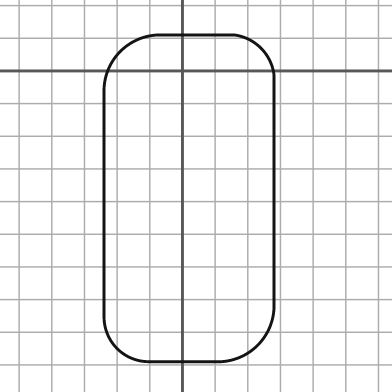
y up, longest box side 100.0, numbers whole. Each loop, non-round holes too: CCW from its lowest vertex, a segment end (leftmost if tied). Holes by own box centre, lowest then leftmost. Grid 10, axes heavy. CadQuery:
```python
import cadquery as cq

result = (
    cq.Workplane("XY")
    .moveTo(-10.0, -89.0)
    .lineTo(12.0, -89.0)
    .threePointArc((23.0, -84.0), (28.0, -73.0))
    .lineTo(28.0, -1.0)
    .threePointArc((24.0, 7.0), (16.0, 11.0))
    .lineTo(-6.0, 11.0)
    .threePointArc((-19.0, 6.0), (-24.0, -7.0))
    .lineTo(-24.0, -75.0)
    .threePointArc((-20.0, -85.0), (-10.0, -89.0))
    .close()
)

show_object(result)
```